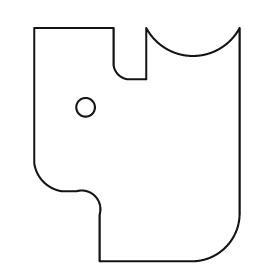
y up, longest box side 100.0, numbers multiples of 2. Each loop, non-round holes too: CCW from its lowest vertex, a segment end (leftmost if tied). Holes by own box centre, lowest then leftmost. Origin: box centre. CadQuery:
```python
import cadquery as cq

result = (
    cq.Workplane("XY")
    .moveTo(-16.0, -50.0)
    .lineTo(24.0, -50.0)
    .threePointArc((38.0, -44.0), (44.0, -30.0))
    .lineTo(44.0, 50.0)
    .threePointArc((24.0, 38.0), (4.0, 50.0))
    .lineTo(4.0, 28.0)
    .lineTo(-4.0, 28.0)
    .threePointArc((-8.0, 30.0), (-10.0, 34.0))
    .lineTo(-10.0, 50.0)
    .lineTo(-44.0, 50.0)
    .lineTo(-44.0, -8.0)
    .threePointArc((-40.0, -16.0), (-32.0, -20.0))
    .lineTo(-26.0, -20.0)
    .threePointArc((-18.0, -22.0), (-16.0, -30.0))
    .close()
    .moveTo(-22.0, 16.0)
    .circle(4.0)
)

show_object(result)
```